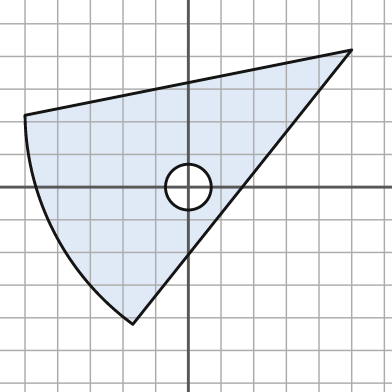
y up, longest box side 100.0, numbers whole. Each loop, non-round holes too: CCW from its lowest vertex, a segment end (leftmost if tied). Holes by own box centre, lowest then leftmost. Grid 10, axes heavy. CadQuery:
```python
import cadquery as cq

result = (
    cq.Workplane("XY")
    .moveTo(-17.0, -42.0)
    .lineTo(50.0, 42.0)
    .lineTo(-50.0, 22.0)
    .threePointArc((-41.0, -14.0), (-17.0, -42.0))
    .close()
    .moveTo(0.0, 0.0)
    .circle(7.0)
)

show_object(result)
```